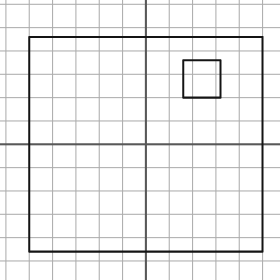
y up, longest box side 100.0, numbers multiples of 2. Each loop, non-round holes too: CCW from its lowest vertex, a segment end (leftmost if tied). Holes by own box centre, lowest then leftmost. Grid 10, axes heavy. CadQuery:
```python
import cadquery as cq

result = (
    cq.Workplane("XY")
    .moveTo(-50.0, -46.0)
    .lineTo(50.0, -46.0)
    .lineTo(50.0, 46.0)
    .lineTo(-50.0, 46.0)
    .close()
    .moveTo(16.0, 20.0)
    .lineTo(32.0, 20.0)
    .lineTo(32.0, 36.0)
    .lineTo(16.0, 36.0)
    .close()
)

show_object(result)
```